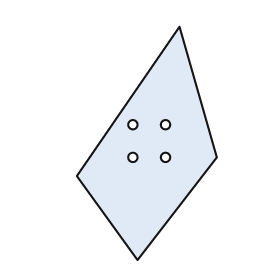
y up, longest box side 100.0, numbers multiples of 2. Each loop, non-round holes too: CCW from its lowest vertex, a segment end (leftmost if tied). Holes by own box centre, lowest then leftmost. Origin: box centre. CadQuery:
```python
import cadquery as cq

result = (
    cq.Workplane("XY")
    .moveTo(-4.0, -50.0)
    .lineTo(30.0, -6.0)
    .lineTo(14.0, 50.0)
    .lineTo(-30.0, -14.0)
    .close()
    .moveTo(-6.0, -6.0)
    .circle(2.0)
    .moveTo(8.0, -6.0)
    .circle(2.0)
    .moveTo(-6.0, 8.0)
    .circle(2.0)
    .moveTo(8.0, 8.0)
    .circle(2.0)
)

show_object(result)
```